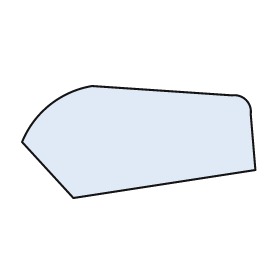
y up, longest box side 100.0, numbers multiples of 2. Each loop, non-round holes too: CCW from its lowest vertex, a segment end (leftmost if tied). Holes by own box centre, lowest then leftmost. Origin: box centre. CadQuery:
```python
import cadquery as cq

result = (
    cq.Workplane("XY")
    .moveTo(-28.0, -24.0)
    .lineTo(50.0, -12.0)
    .lineTo(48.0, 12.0)
    .threePointArc((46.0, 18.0), (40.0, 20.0))
    .lineTo(-20.0, 24.0)
    .threePointArc((-38.0, 16.0), (-50.0, 0.0))
    .close()
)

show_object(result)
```